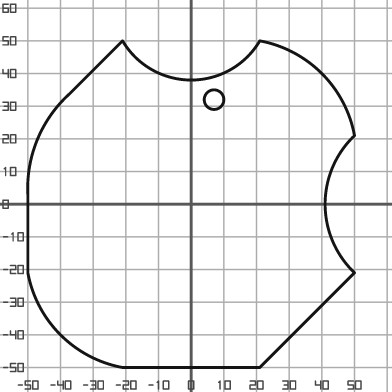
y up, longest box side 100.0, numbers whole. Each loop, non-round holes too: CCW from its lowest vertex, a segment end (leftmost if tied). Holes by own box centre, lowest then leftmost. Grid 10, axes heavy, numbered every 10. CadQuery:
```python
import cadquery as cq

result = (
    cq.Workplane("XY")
    .moveTo(-21.0, -50.0)
    .lineTo(21.0, -50.0)
    .lineTo(50.0, -21.0)
    .threePointArc((41.0, 0.0), (50.0, 21.0))
    .threePointArc((40.0, 40.0), (21.0, 50.0))
    .threePointArc((0.0, 38.0), (-21.0, 50.0))
    .lineTo(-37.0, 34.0)
    .threePointArc((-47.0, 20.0), (-50.0, 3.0))
    .lineTo(-50.0, -21.0)
    .threePointArc((-40.0, -40.0), (-21.0, -50.0))
    .close()
    .moveTo(7.0, 32.0)
    .circle(3.0)
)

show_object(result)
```